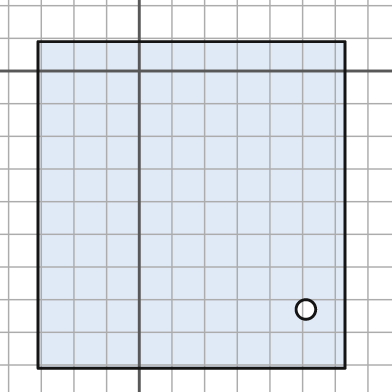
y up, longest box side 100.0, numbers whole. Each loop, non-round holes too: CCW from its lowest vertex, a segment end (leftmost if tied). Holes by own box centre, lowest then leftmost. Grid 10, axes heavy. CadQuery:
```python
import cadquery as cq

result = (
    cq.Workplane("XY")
    .moveTo(-31.0, -91.0)
    .lineTo(63.0, -91.0)
    .lineTo(63.0, 9.0)
    .lineTo(-31.0, 9.0)
    .close()
    .moveTo(51.0, -73.0)
    .circle(3.0)
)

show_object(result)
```